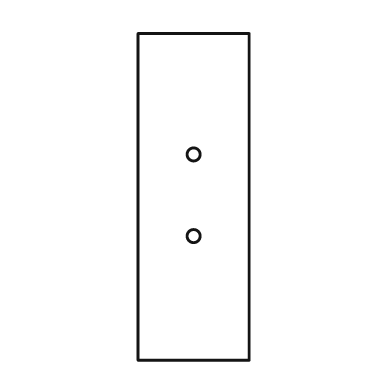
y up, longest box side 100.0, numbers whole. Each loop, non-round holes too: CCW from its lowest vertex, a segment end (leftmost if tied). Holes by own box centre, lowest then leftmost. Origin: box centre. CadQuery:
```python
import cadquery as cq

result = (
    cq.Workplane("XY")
    .moveTo(-17.0, -50.0)
    .lineTo(17.0, -50.0)
    .lineTo(17.0, 50.0)
    .lineTo(-17.0, 50.0)
    .close()
    .moveTo(0.0, -12.0)
    .circle(2.0)
    .moveTo(0.0, 13.0)
    .circle(2.0)
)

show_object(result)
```